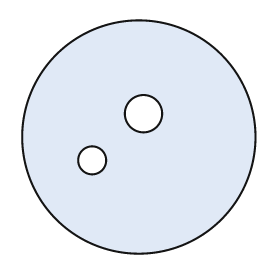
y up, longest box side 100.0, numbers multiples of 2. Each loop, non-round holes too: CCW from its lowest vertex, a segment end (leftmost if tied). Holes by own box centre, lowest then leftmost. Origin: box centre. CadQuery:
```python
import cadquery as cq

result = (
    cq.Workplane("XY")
    .moveTo(0.0, 0.0)
    .circle(50.0)
    .moveTo(-20.0, -10.0)
    .circle(6.0)
    .moveTo(2.0, 10.0)
    .circle(8.0)
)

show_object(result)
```